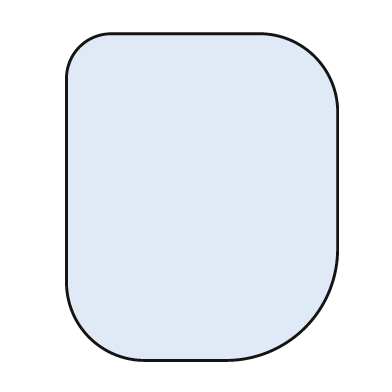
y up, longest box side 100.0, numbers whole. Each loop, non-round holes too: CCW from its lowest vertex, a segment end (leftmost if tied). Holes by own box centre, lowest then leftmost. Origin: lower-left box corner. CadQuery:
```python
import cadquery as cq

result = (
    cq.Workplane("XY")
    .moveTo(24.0, 0.0)
    .lineTo(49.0, 0.0)
    .threePointArc((73.0, 10.0), (83.0, 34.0))
    .lineTo(83.0, 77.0)
    .threePointArc((76.0, 93.0), (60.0, 100.0))
    .lineTo(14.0, 100.0)
    .threePointArc((4.0, 96.0), (0.0, 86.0))
    .lineTo(0.0, 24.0)
    .threePointArc((7.0, 7.0), (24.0, 0.0))
    .close()
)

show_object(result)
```